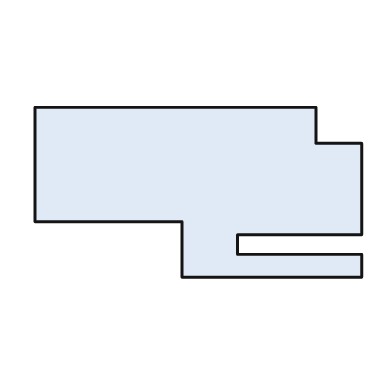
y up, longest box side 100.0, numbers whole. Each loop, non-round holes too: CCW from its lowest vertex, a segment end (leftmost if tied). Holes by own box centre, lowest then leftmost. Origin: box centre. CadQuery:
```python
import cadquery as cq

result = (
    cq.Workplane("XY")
    .moveTo(-5.0, -26.0)
    .lineTo(50.0, -26.0)
    .lineTo(50.0, -19.0)
    .lineTo(12.0, -19.0)
    .lineTo(12.0, -13.0)
    .lineTo(50.0, -13.0)
    .lineTo(50.0, 15.0)
    .lineTo(36.0, 15.0)
    .lineTo(36.0, 26.0)
    .lineTo(-50.0, 26.0)
    .lineTo(-50.0, -9.0)
    .lineTo(-5.0, -9.0)
    .close()
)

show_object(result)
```